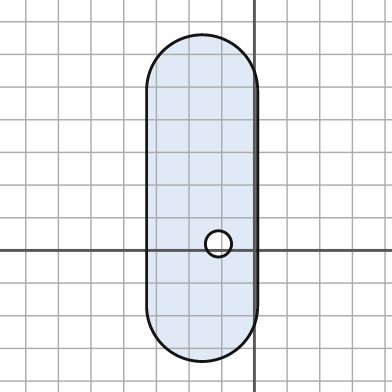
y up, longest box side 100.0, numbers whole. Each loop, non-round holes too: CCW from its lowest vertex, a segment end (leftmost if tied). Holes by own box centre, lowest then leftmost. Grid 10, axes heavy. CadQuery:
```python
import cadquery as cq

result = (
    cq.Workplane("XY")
    .moveTo(-33.0, -17.0)
    .threePointArc((-16.0, -34.0), (1.0, -17.0))
    .lineTo(1.0, 49.0)
    .threePointArc((-16.0, 66.0), (-33.0, 49.0))
    .close()
    .moveTo(-11.0, 2.0)
    .circle(4.0)
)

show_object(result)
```